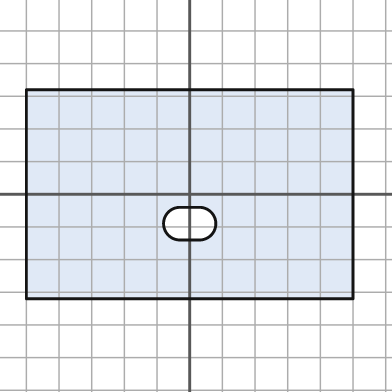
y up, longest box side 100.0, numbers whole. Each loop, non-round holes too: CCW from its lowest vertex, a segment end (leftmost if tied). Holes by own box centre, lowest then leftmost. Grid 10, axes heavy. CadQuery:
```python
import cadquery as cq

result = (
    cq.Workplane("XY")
    .moveTo(-50.0, -32.0)
    .lineTo(50.0, -32.0)
    .lineTo(50.0, 32.0)
    .lineTo(-50.0, 32.0)
    .close()
    .moveTo(-3.0, -14.0)
    .lineTo(3.0, -14.0)
    .threePointArc((8.0, -9.0), (3.0, -4.0))
    .lineTo(-3.0, -4.0)
    .threePointArc((-8.0, -9.0), (-3.0, -14.0))
    .close()
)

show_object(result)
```